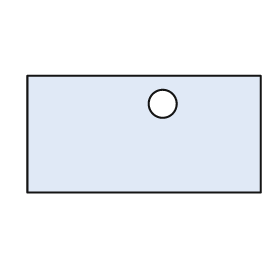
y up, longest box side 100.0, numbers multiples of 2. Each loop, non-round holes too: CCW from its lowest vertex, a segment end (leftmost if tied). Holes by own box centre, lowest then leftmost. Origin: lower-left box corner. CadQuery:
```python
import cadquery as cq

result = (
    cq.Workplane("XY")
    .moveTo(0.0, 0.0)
    .lineTo(100.0, 0.0)
    .lineTo(100.0, 50.0)
    .lineTo(0.0, 50.0)
    .close()
    .moveTo(58.0, 38.0)
    .circle(6.0)
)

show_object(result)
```